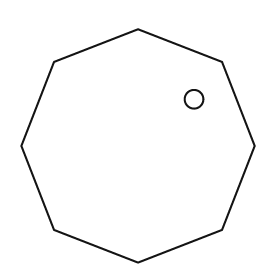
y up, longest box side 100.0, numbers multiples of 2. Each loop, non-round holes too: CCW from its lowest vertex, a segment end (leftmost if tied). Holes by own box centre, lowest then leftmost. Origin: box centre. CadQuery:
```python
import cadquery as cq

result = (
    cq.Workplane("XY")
    .moveTo(0.0, -50.0)
    .lineTo(36.0, -36.0)
    .lineTo(50.0, 0.0)
    .lineTo(36.0, 36.0)
    .lineTo(0.0, 50.0)
    .lineTo(-36.0, 36.0)
    .lineTo(-50.0, 0.0)
    .lineTo(-36.0, -36.0)
    .close()
    .moveTo(24.0, 20.0)
    .circle(4.0)
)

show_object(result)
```